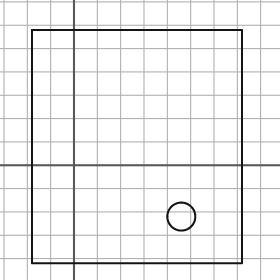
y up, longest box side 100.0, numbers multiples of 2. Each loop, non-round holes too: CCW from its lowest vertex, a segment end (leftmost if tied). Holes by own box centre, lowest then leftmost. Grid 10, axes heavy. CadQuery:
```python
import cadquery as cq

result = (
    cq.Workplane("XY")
    .moveTo(-18.0, -42.0)
    .lineTo(72.0, -42.0)
    .lineTo(72.0, 58.0)
    .lineTo(-18.0, 58.0)
    .close()
    .moveTo(46.0, -22.0)
    .circle(6.0)
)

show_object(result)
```